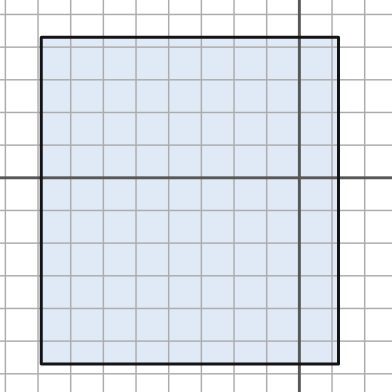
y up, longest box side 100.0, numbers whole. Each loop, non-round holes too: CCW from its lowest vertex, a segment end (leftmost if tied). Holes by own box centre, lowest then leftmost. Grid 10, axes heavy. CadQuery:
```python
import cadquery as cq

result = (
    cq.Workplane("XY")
    .moveTo(-79.0, -57.0)
    .lineTo(12.0, -57.0)
    .lineTo(12.0, 43.0)
    .lineTo(-79.0, 43.0)
    .close()
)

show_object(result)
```